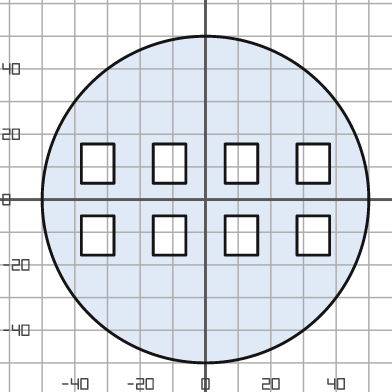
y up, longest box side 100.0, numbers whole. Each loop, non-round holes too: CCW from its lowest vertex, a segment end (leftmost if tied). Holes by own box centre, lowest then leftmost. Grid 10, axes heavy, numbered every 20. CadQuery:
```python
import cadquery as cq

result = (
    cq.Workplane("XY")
    .moveTo(0.0, 0.0)
    .circle(50.0)
    .moveTo(-38.0, -17.0)
    .lineTo(-28.0, -17.0)
    .lineTo(-28.0, -5.0)
    .lineTo(-38.0, -5.0)
    .close()
    .moveTo(-16.0, -17.0)
    .lineTo(-6.0, -17.0)
    .lineTo(-6.0, -5.0)
    .lineTo(-16.0, -5.0)
    .close()
    .moveTo(6.0, -17.0)
    .lineTo(16.0, -17.0)
    .lineTo(16.0, -5.0)
    .lineTo(6.0, -5.0)
    .close()
    .moveTo(28.0, -17.0)
    .lineTo(38.0, -17.0)
    .lineTo(38.0, -5.0)
    .lineTo(28.0, -5.0)
    .close()
    .moveTo(-38.0, 5.0)
    .lineTo(-28.0, 5.0)
    .lineTo(-28.0, 17.0)
    .lineTo(-38.0, 17.0)
    .close()
    .moveTo(-16.0, 5.0)
    .lineTo(-6.0, 5.0)
    .lineTo(-6.0, 17.0)
    .lineTo(-16.0, 17.0)
    .close()
    .moveTo(6.0, 5.0)
    .lineTo(16.0, 5.0)
    .lineTo(16.0, 17.0)
    .lineTo(6.0, 17.0)
    .close()
    .moveTo(28.0, 5.0)
    .lineTo(38.0, 5.0)
    .lineTo(38.0, 17.0)
    .lineTo(28.0, 17.0)
    .close()
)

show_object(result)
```